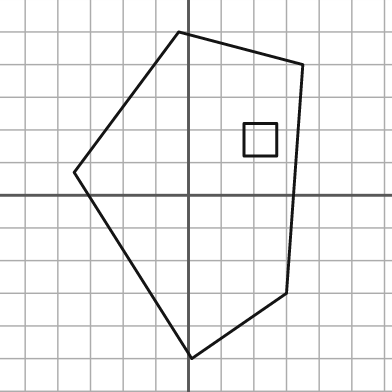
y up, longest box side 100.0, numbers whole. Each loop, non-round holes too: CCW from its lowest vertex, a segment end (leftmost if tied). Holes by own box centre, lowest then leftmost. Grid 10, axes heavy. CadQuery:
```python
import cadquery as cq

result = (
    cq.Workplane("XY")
    .moveTo(1.0, -50.0)
    .lineTo(30.0, -30.0)
    .lineTo(35.0, 40.0)
    .lineTo(-3.0, 50.0)
    .lineTo(-35.0, 7.0)
    .close()
    .moveTo(17.0, 12.0)
    .lineTo(27.0, 12.0)
    .lineTo(27.0, 22.0)
    .lineTo(17.0, 22.0)
    .close()
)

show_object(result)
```